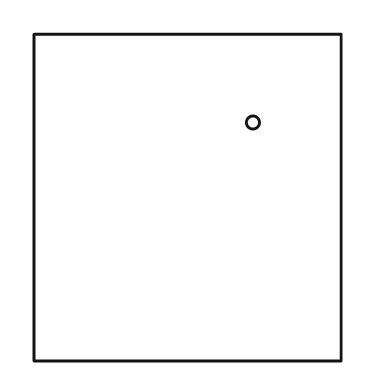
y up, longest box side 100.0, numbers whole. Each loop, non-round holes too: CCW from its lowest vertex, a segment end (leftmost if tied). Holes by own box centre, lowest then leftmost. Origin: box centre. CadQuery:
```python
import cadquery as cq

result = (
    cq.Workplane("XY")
    .moveTo(-47.0, -50.0)
    .lineTo(47.0, -50.0)
    .lineTo(47.0, 50.0)
    .lineTo(-47.0, 50.0)
    .close()
    .moveTo(20.0, 23.0)
    .circle(2.0)
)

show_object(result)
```